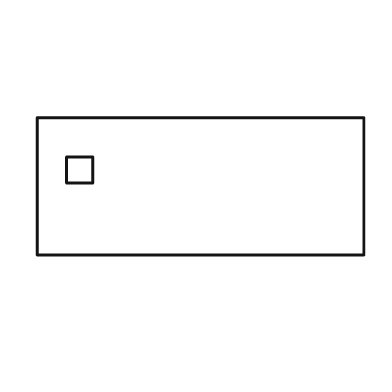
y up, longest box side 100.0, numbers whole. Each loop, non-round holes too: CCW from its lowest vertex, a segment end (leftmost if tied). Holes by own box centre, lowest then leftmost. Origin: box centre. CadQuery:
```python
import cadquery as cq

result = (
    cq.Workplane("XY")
    .moveTo(-50.0, -21.0)
    .lineTo(50.0, -21.0)
    .lineTo(50.0, 21.0)
    .lineTo(-50.0, 21.0)
    .close()
    .moveTo(-41.0, 1.0)
    .lineTo(-33.0, 1.0)
    .lineTo(-33.0, 9.0)
    .lineTo(-41.0, 9.0)
    .close()
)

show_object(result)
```